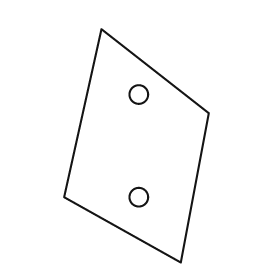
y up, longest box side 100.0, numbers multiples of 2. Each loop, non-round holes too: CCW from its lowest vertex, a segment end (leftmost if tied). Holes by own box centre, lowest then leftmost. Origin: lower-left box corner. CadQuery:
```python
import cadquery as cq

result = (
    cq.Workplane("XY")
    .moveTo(50.0, 0.0)
    .lineTo(62.0, 64.0)
    .lineTo(16.0, 100.0)
    .lineTo(0.0, 28.0)
    .close()
    .moveTo(32.0, 28.0)
    .circle(4.0)
    .moveTo(32.0, 72.0)
    .circle(4.0)
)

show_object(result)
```